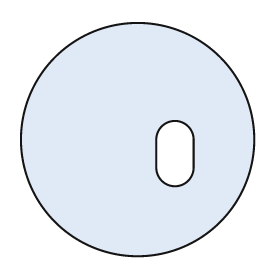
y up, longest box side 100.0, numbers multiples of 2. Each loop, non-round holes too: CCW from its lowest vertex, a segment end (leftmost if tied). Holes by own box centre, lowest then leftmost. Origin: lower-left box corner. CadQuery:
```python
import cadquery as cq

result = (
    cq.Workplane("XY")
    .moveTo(50.0, 50.0)
    .circle(50.0)
    .moveTo(58.0, 38.0)
    .threePointArc((66.0, 30.0), (74.0, 38.0))
    .lineTo(74.0, 50.0)
    .threePointArc((66.0, 58.0), (58.0, 50.0))
    .close()
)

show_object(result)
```